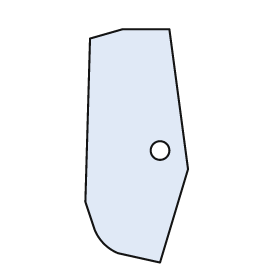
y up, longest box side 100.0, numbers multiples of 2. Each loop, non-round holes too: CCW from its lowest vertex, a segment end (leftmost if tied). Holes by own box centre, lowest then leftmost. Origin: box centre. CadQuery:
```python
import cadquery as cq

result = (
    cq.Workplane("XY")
    .moveTo(10.0, -50.0)
    .lineTo(22.0, -10.0)
    .lineTo(14.0, 50.0)
    .lineTo(-6.0, 50.0)
    .lineTo(-20.0, 46.0)
    .lineTo(-22.0, -24.0)
    .lineTo(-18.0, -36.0)
    .threePointArc((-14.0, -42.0), (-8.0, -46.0))
    .close()
    .moveTo(10.0, -2.0)
    .circle(4.0)
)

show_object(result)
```